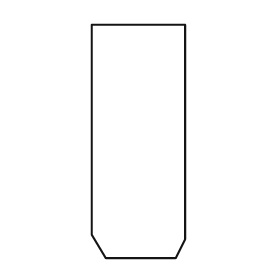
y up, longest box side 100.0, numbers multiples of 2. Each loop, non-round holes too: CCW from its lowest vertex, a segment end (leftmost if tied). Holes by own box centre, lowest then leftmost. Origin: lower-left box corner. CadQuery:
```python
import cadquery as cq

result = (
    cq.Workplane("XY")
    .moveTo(6.0, 0.0)
    .lineTo(36.0, 0.0)
    .lineTo(40.0, 8.0)
    .lineTo(40.0, 100.0)
    .lineTo(0.0, 100.0)
    .lineTo(0.0, 10.0)
    .close()
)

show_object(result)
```